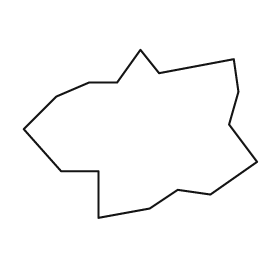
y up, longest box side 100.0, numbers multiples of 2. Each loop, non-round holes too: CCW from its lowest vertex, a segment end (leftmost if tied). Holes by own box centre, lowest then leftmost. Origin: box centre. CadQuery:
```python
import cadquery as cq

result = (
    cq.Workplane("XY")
    .moveTo(-18.0, -36.0)
    .lineTo(4.0, -32.0)
    .lineTo(16.0, -24.0)
    .lineTo(30.0, -26.0)
    .lineTo(50.0, -12.0)
    .lineTo(38.0, 4.0)
    .lineTo(42.0, 18.0)
    .lineTo(40.0, 32.0)
    .lineTo(8.0, 26.0)
    .lineTo(0.0, 36.0)
    .lineTo(-10.0, 22.0)
    .lineTo(-22.0, 22.0)
    .lineTo(-36.0, 16.0)
    .lineTo(-50.0, 2.0)
    .lineTo(-34.0, -16.0)
    .lineTo(-18.0, -16.0)
    .close()
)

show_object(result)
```